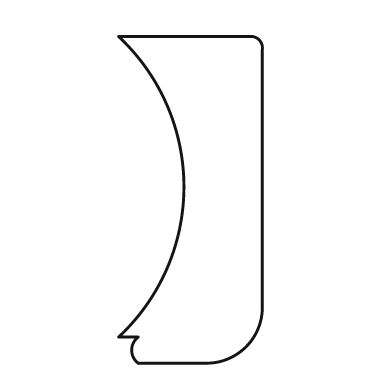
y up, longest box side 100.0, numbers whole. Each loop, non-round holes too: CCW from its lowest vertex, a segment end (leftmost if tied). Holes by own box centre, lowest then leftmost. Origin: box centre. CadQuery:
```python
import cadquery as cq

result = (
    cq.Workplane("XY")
    .moveTo(-16.0, -50.0)
    .lineTo(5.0, -50.0)
    .threePointArc((17.0, -45.0), (22.0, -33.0))
    .lineTo(22.0, 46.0)
    .threePointArc((21.0, 49.0), (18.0, 50.0))
    .lineTo(-22.0, 50.0)
    .threePointArc((-2.0, 4.0), (-22.0, -42.0))
    .lineTo(-16.0, -42.0)
    .threePointArc((-18.0, -46.0), (-16.0, -50.0))
    .close()
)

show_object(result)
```